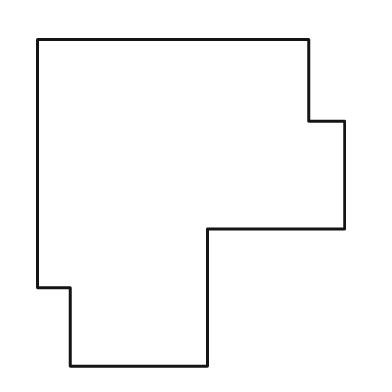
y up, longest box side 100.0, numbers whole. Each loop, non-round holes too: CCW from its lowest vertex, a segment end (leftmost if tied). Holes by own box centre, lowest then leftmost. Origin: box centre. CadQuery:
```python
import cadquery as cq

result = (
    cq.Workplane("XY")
    .moveTo(-37.0, -50.0)
    .lineTo(5.0, -50.0)
    .lineTo(5.0, -8.0)
    .lineTo(47.0, -8.0)
    .lineTo(47.0, 25.0)
    .lineTo(36.0, 25.0)
    .lineTo(36.0, 50.0)
    .lineTo(-47.0, 50.0)
    .lineTo(-47.0, -26.0)
    .lineTo(-37.0, -26.0)
    .close()
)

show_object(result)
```